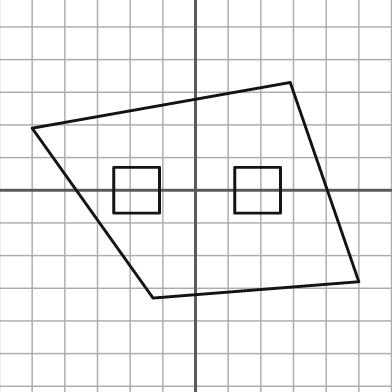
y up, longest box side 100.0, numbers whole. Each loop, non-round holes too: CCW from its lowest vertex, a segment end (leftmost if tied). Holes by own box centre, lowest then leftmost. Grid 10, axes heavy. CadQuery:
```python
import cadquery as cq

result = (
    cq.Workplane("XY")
    .moveTo(-13.0, -33.0)
    .lineTo(50.0, -28.0)
    .lineTo(29.0, 33.0)
    .lineTo(-50.0, 19.0)
    .close()
    .moveTo(-25.0, -7.0)
    .lineTo(-11.0, -7.0)
    .lineTo(-11.0, 7.0)
    .lineTo(-25.0, 7.0)
    .close()
    .moveTo(12.0, -7.0)
    .lineTo(26.0, -7.0)
    .lineTo(26.0, 7.0)
    .lineTo(12.0, 7.0)
    .close()
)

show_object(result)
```